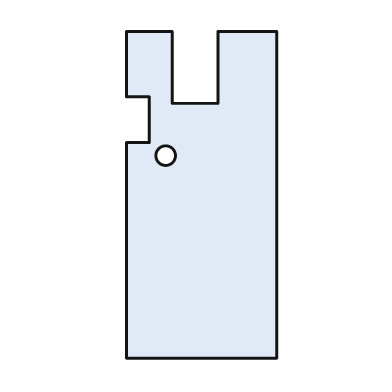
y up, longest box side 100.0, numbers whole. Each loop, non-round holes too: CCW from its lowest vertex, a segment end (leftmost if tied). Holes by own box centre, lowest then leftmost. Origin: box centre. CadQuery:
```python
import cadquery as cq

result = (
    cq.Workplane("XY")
    .moveTo(-23.0, -50.0)
    .lineTo(23.0, -50.0)
    .lineTo(23.0, 50.0)
    .lineTo(5.0, 50.0)
    .lineTo(5.0, 28.0)
    .lineTo(-9.0, 28.0)
    .lineTo(-9.0, 50.0)
    .lineTo(-23.0, 50.0)
    .lineTo(-23.0, 30.0)
    .lineTo(-16.0, 30.0)
    .lineTo(-16.0, 16.0)
    .lineTo(-23.0, 16.0)
    .close()
    .moveTo(-11.0, 12.0)
    .circle(3.0)
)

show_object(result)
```